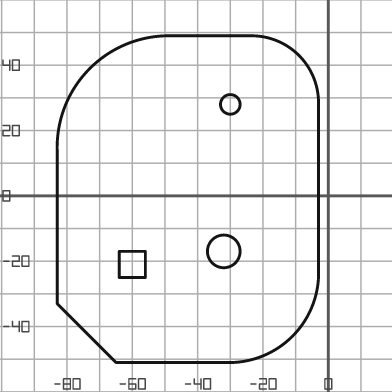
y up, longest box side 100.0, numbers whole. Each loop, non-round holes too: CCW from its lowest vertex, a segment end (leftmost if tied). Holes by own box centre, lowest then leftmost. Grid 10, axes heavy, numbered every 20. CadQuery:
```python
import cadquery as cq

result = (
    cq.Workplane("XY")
    .moveTo(-65.0, -51.0)
    .lineTo(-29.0, -51.0)
    .threePointArc((-11.0, -43.0), (-3.0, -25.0))
    .lineTo(-3.0, 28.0)
    .threePointArc((-9.0, 43.0), (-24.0, 49.0))
    .lineTo(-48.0, 49.0)
    .threePointArc((-73.0, 39.0), (-83.0, 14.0))
    .lineTo(-83.0, -33.0)
    .close()
    .moveTo(-64.0, -25.0)
    .lineTo(-56.0, -25.0)
    .lineTo(-56.0, -17.0)
    .lineTo(-64.0, -17.0)
    .close()
    .moveTo(-32.0, -17.0)
    .circle(5.0)
    .moveTo(-30.0, 28.0)
    .circle(3.0)
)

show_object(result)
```